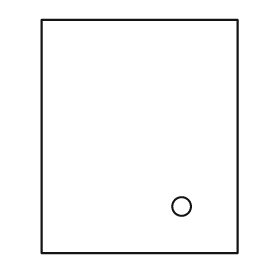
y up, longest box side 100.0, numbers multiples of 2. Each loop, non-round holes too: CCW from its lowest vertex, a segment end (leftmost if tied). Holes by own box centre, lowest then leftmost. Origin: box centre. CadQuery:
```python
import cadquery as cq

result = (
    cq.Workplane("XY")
    .moveTo(-42.0, -50.0)
    .lineTo(42.0, -50.0)
    .lineTo(42.0, 50.0)
    .lineTo(-42.0, 50.0)
    .close()
    .moveTo(18.0, -30.0)
    .circle(4.0)
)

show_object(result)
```